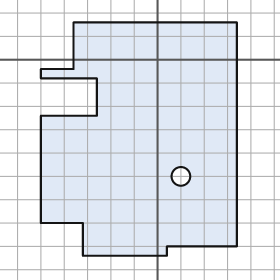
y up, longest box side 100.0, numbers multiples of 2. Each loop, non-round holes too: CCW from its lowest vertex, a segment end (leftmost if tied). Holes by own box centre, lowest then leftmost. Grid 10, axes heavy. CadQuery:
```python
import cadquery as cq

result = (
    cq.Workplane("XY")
    .moveTo(-32.0, -84.0)
    .lineTo(4.0, -84.0)
    .lineTo(4.0, -80.0)
    .lineTo(34.0, -80.0)
    .lineTo(34.0, 16.0)
    .lineTo(-36.0, 16.0)
    .lineTo(-36.0, -4.0)
    .lineTo(-50.0, -4.0)
    .lineTo(-50.0, -8.0)
    .lineTo(-26.0, -8.0)
    .lineTo(-26.0, -24.0)
    .lineTo(-50.0, -24.0)
    .lineTo(-50.0, -70.0)
    .lineTo(-32.0, -70.0)
    .close()
    .moveTo(10.0, -50.0)
    .circle(4.0)
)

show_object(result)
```